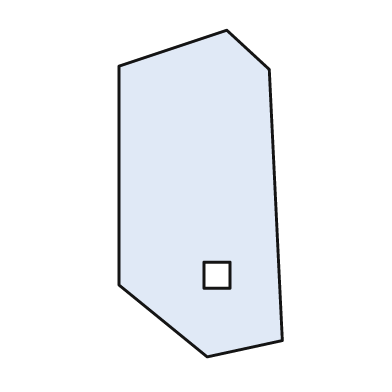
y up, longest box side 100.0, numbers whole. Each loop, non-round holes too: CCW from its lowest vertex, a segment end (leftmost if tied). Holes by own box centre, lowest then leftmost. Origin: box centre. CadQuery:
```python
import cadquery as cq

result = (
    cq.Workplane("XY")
    .moveTo(2.0, -50.0)
    .lineTo(25.0, -45.0)
    .lineTo(21.0, 38.0)
    .lineTo(8.0, 50.0)
    .lineTo(-25.0, 39.0)
    .lineTo(-25.0, -28.0)
    .close()
    .moveTo(1.0, -29.0)
    .lineTo(9.0, -29.0)
    .lineTo(9.0, -21.0)
    .lineTo(1.0, -21.0)
    .close()
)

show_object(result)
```